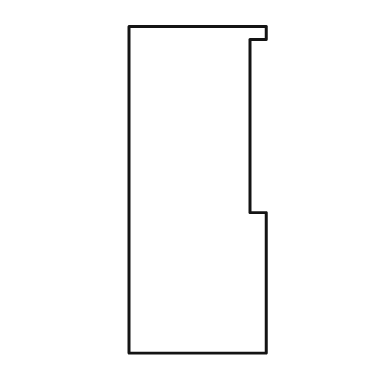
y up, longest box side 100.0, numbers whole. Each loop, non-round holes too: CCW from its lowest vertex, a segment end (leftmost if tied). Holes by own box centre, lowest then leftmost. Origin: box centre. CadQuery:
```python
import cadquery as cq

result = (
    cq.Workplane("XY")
    .moveTo(-21.0, -50.0)
    .lineTo(21.0, -50.0)
    .lineTo(21.0, -7.0)
    .lineTo(16.0, -7.0)
    .lineTo(16.0, 46.0)
    .lineTo(21.0, 46.0)
    .lineTo(21.0, 50.0)
    .lineTo(-21.0, 50.0)
    .close()
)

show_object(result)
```